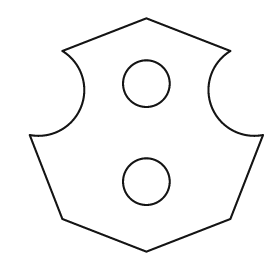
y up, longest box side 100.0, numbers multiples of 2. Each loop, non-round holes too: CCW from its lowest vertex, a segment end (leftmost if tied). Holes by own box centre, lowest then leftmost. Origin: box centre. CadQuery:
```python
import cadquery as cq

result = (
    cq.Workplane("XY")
    .moveTo(0.0, -50.0)
    .lineTo(36.0, -36.0)
    .lineTo(50.0, 0.0)
    .threePointArc((28.0, 12.0), (36.0, 36.0))
    .lineTo(0.0, 50.0)
    .lineTo(-36.0, 36.0)
    .threePointArc((-28.0, 12.0), (-50.0, 0.0))
    .lineTo(-36.0, -36.0)
    .close()
    .moveTo(0.0, -20.0)
    .circle(10.0)
    .moveTo(0.0, 22.0)
    .circle(10.0)
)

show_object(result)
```